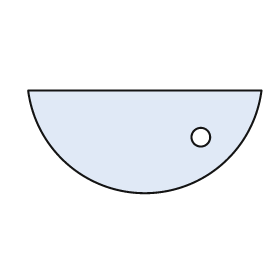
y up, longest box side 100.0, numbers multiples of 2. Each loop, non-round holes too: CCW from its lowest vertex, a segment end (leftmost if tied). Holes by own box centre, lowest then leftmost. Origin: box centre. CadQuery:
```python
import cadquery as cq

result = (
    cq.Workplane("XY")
    .moveTo(-50.0, 22.0)
    .threePointArc((0.0, -22.0), (50.0, 22.0))
    .close()
    .moveTo(24.0, 2.0)
    .circle(4.0)
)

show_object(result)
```